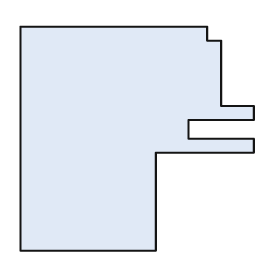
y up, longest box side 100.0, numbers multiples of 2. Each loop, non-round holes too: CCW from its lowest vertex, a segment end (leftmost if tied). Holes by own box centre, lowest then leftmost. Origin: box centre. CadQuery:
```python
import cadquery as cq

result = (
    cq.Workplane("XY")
    .moveTo(-50.0, -48.0)
    .lineTo(8.0, -48.0)
    .lineTo(8.0, -6.0)
    .lineTo(50.0, -6.0)
    .lineTo(50.0, 0.0)
    .lineTo(22.0, 0.0)
    .lineTo(22.0, 8.0)
    .lineTo(50.0, 8.0)
    .lineTo(50.0, 14.0)
    .lineTo(36.0, 14.0)
    .lineTo(36.0, 42.0)
    .lineTo(30.0, 42.0)
    .lineTo(30.0, 48.0)
    .lineTo(-50.0, 48.0)
    .close()
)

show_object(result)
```